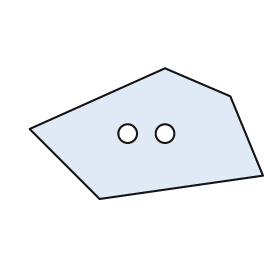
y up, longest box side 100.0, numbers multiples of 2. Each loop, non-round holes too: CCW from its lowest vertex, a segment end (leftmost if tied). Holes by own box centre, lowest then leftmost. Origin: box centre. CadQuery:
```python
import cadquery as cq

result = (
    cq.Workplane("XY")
    .moveTo(-20.0, -28.0)
    .lineTo(50.0, -18.0)
    .lineTo(36.0, 16.0)
    .lineTo(8.0, 28.0)
    .lineTo(-50.0, 2.0)
    .close()
    .moveTo(-8.0, 0.0)
    .circle(4.0)
    .moveTo(8.0, 0.0)
    .circle(4.0)
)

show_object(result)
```